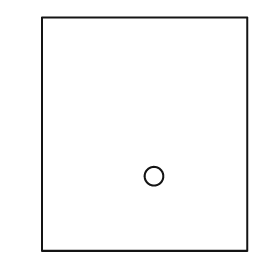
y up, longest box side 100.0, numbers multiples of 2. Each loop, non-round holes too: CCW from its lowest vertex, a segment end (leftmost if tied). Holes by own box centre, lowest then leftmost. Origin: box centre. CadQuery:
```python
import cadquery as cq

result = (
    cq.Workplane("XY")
    .moveTo(-44.0, -50.0)
    .lineTo(44.0, -50.0)
    .lineTo(44.0, 50.0)
    .lineTo(-44.0, 50.0)
    .close()
    .moveTo(4.0, -18.0)
    .circle(4.0)
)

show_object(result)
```